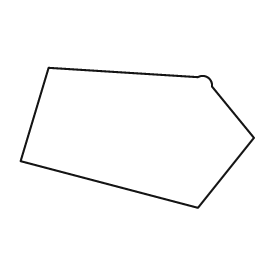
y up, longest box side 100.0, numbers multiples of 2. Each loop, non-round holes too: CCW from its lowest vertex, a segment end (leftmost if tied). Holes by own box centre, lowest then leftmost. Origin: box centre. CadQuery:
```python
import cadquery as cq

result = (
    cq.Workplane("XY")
    .moveTo(26.0, -30.0)
    .lineTo(50.0, 0.0)
    .lineTo(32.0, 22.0)
    .threePointArc((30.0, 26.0), (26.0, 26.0))
    .lineTo(-38.0, 30.0)
    .lineTo(-50.0, -10.0)
    .close()
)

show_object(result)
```